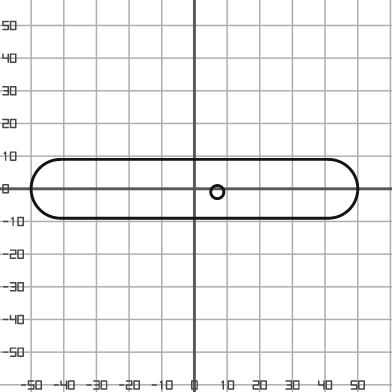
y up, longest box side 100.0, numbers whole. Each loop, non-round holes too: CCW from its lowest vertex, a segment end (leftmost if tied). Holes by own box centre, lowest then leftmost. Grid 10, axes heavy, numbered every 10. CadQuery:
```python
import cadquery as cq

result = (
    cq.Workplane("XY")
    .moveTo(-41.0, -9.0)
    .lineTo(41.0, -9.0)
    .threePointArc((50.0, 0.0), (41.0, 9.0))
    .lineTo(-41.0, 9.0)
    .threePointArc((-50.0, 0.0), (-41.0, -9.0))
    .close()
    .moveTo(7.0, -1.0)
    .circle(2.0)
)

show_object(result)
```